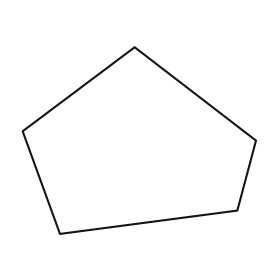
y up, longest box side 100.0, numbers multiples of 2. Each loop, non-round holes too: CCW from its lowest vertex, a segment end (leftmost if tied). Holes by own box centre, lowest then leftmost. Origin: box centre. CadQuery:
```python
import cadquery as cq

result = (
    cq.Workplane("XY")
    .moveTo(-34.0, -40.0)
    .lineTo(42.0, -30.0)
    .lineTo(50.0, 0.0)
    .lineTo(-2.0, 40.0)
    .lineTo(-50.0, 4.0)
    .close()
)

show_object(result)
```